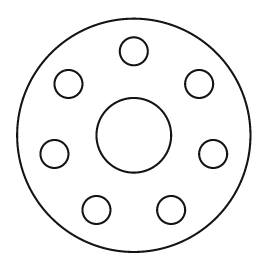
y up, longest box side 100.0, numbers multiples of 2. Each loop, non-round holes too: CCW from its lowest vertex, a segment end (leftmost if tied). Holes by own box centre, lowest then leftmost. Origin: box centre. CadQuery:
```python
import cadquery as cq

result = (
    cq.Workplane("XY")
    .moveTo(0.0, 0.0)
    .circle(50.0)
    .moveTo(-16.0, -32.0)
    .circle(6.0)
    .moveTo(16.0, -32.0)
    .circle(6.0)
    .moveTo(-34.0, -8.0)
    .circle(6.0)
    .moveTo(34.0, -8.0)
    .circle(6.0)
    .moveTo(0.0, 0.0)
    .circle(16.0)
    .moveTo(-28.0, 22.0)
    .circle(6.0)
    .moveTo(28.0, 22.0)
    .circle(6.0)
    .moveTo(0.0, 36.0)
    .circle(6.0)
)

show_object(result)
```